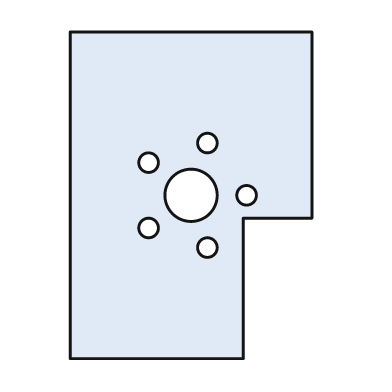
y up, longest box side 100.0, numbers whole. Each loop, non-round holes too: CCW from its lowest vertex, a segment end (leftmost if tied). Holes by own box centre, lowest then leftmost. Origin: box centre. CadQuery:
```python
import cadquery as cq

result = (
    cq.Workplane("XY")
    .moveTo(-37.0, -50.0)
    .lineTo(16.0, -50.0)
    .lineTo(16.0, -7.0)
    .lineTo(37.0, -7.0)
    .lineTo(37.0, 50.0)
    .lineTo(-37.0, 50.0)
    .close()
    .moveTo(5.0, -16.0)
    .circle(3.0)
    .moveTo(-13.0, -10.0)
    .circle(3.0)
    .moveTo(0.0, 0.0)
    .circle(8.0)
    .moveTo(17.0, 0.0)
    .circle(3.0)
    .moveTo(-13.0, 10.0)
    .circle(3.0)
    .moveTo(5.0, 16.0)
    .circle(3.0)
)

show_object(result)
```